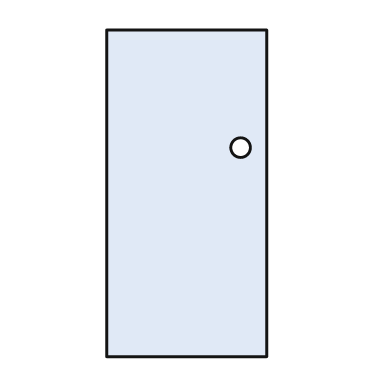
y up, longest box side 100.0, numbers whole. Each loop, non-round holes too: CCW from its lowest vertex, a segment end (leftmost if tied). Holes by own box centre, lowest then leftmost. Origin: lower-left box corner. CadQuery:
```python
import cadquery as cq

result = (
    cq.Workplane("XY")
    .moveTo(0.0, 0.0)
    .lineTo(49.0, 0.0)
    .lineTo(49.0, 100.0)
    .lineTo(0.0, 100.0)
    .close()
    .moveTo(41.0, 64.0)
    .circle(3.0)
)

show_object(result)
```